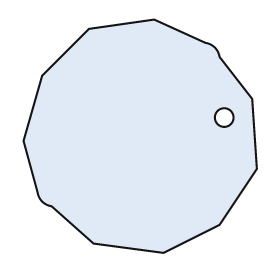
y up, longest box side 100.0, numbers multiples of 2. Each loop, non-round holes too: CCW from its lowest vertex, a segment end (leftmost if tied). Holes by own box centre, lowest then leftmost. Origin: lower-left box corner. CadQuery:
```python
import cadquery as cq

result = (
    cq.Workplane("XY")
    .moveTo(60.0, 0.0)
    .lineTo(84.0, 12.0)
    .lineTo(100.0, 36.0)
    .lineTo(98.0, 66.0)
    .lineTo(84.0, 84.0)
    .threePointArc((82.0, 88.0), (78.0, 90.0))
    .lineTo(56.0, 100.0)
    .lineTo(28.0, 96.0)
    .lineTo(8.0, 76.0)
    .lineTo(0.0, 48.0)
    .lineTo(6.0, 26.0)
    .threePointArc((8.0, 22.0), (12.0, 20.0))
    .lineTo(30.0, 4.0)
    .close()
    .moveTo(86.0, 58.0)
    .circle(4.0)
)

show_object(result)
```